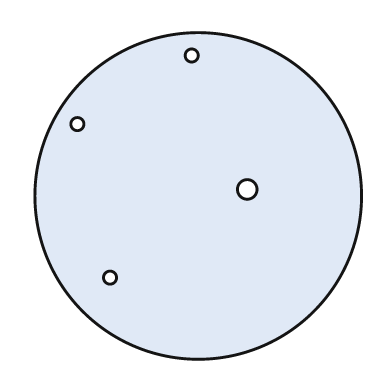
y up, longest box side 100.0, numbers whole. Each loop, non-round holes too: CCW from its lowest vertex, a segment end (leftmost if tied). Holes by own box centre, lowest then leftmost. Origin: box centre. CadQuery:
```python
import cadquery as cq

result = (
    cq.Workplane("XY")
    .moveTo(0.0, 0.0)
    .circle(50.0)
    .moveTo(-27.0, -25.0)
    .circle(2.0)
    .moveTo(15.0, 2.0)
    .circle(3.0)
    .moveTo(-37.0, 22.0)
    .circle(2.0)
    .moveTo(-2.0, 43.0)
    .circle(2.0)
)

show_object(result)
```